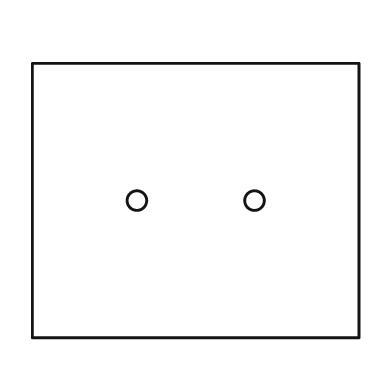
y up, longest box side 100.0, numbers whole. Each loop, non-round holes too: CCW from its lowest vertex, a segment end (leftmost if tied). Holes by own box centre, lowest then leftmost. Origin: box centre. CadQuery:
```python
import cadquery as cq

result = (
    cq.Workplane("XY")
    .moveTo(-50.0, -42.0)
    .lineTo(50.0, -42.0)
    .lineTo(50.0, 42.0)
    .lineTo(-50.0, 42.0)
    .close()
    .moveTo(-18.0, 0.0)
    .circle(3.0)
    .moveTo(18.0, 0.0)
    .circle(3.0)
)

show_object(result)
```